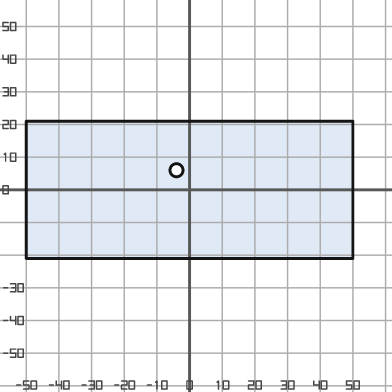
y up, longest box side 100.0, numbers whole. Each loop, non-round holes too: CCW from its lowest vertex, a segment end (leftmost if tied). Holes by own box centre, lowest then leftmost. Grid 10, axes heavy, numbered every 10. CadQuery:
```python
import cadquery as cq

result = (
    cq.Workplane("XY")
    .moveTo(-50.0, -21.0)
    .lineTo(50.0, -21.0)
    .lineTo(50.0, 21.0)
    .lineTo(-50.0, 21.0)
    .close()
    .moveTo(-4.0, 6.0)
    .circle(2.0)
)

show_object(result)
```